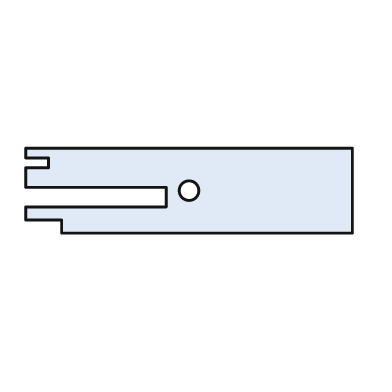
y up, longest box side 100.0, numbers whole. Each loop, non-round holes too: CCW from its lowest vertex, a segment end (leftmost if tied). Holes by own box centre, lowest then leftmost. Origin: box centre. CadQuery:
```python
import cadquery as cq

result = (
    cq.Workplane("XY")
    .moveTo(-39.0, -13.0)
    .lineTo(50.0, -13.0)
    .lineTo(50.0, 13.0)
    .lineTo(-50.0, 13.0)
    .lineTo(-50.0, 10.0)
    .lineTo(-43.0, 10.0)
    .lineTo(-43.0, 7.0)
    .lineTo(-50.0, 7.0)
    .lineTo(-50.0, 1.0)
    .lineTo(-7.0, 1.0)
    .lineTo(-7.0, -5.0)
    .lineTo(-50.0, -5.0)
    .lineTo(-50.0, -9.0)
    .lineTo(-39.0, -9.0)
    .close()
    .moveTo(0.0, 0.0)
    .circle(3.0)
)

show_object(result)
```